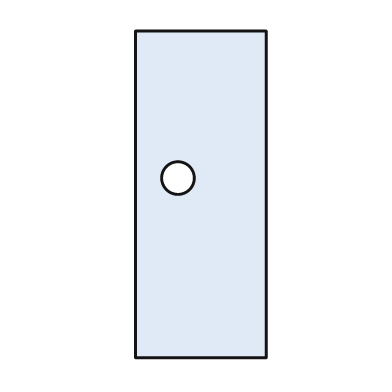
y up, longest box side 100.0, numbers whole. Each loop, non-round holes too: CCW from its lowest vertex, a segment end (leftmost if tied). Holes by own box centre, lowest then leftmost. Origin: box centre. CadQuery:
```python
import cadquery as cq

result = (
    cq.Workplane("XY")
    .moveTo(-20.0, -50.0)
    .lineTo(20.0, -50.0)
    .lineTo(20.0, 50.0)
    .lineTo(-20.0, 50.0)
    .close()
    .moveTo(-7.0, 5.0)
    .circle(5.0)
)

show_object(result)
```